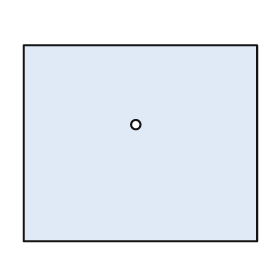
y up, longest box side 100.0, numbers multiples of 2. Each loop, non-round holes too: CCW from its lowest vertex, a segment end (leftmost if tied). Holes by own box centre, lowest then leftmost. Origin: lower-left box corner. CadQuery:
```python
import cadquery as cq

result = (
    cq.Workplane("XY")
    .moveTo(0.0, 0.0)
    .lineTo(100.0, 0.0)
    .lineTo(100.0, 84.0)
    .lineTo(0.0, 84.0)
    .close()
    .moveTo(48.0, 50.0)
    .circle(2.0)
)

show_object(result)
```